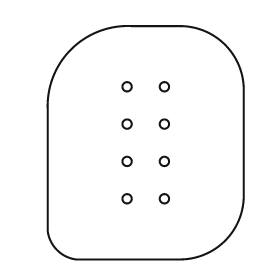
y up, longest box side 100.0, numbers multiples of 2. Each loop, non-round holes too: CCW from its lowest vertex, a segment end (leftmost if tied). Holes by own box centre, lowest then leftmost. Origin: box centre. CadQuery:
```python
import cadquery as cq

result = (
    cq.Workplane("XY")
    .moveTo(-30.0, -50.0)
    .lineTo(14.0, -50.0)
    .threePointArc((34.0, -42.0), (42.0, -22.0))
    .lineTo(42.0, 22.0)
    .threePointArc((34.0, 42.0), (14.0, 50.0))
    .lineTo(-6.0, 50.0)
    .threePointArc((-32.0, 40.0), (-42.0, 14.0))
    .lineTo(-42.0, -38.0)
    .threePointArc((-38.0, -46.0), (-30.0, -50.0))
    .close()
    .moveTo(-8.0, -24.0)
    .circle(2.0)
    .moveTo(8.0, -24.0)
    .circle(2.0)
    .moveTo(-8.0, -8.0)
    .circle(2.0)
    .moveTo(8.0, -8.0)
    .circle(2.0)
    .moveTo(-8.0, 8.0)
    .circle(2.0)
    .moveTo(8.0, 8.0)
    .circle(2.0)
    .moveTo(-8.0, 24.0)
    .circle(2.0)
    .moveTo(8.0, 24.0)
    .circle(2.0)
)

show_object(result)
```